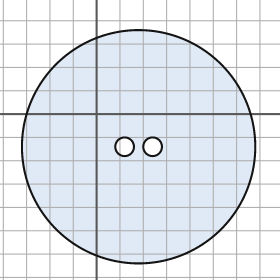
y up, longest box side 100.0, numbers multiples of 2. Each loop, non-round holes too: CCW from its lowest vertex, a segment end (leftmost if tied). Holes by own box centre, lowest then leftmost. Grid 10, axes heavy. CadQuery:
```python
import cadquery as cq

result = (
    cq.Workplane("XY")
    .moveTo(18.0, -14.0)
    .circle(50.0)
    .moveTo(12.0, -14.0)
    .circle(4.0)
    .moveTo(24.0, -14.0)
    .circle(4.0)
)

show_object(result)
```